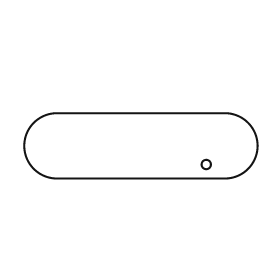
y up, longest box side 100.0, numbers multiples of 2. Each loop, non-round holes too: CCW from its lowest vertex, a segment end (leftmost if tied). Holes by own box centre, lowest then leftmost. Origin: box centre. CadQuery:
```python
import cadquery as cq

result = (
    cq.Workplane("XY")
    .moveTo(-36.0, -14.0)
    .lineTo(36.0, -14.0)
    .threePointArc((50.0, 0.0), (36.0, 14.0))
    .lineTo(-36.0, 14.0)
    .threePointArc((-50.0, 0.0), (-36.0, -14.0))
    .close()
    .moveTo(28.0, -8.0)
    .circle(2.0)
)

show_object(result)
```